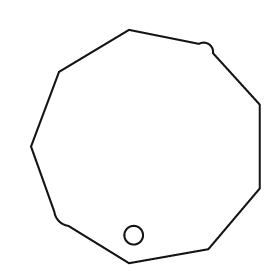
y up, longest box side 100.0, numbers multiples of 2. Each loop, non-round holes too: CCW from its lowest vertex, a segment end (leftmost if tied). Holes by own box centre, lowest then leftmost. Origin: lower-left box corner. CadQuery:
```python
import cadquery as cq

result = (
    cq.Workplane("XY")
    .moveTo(42.0, 0.0)
    .lineTo(76.0, 6.0)
    .lineTo(98.0, 32.0)
    .lineTo(98.0, 68.0)
    .lineTo(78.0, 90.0)
    .threePointArc((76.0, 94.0), (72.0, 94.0))
    .lineTo(42.0, 100.0)
    .lineTo(12.0, 82.0)
    .lineTo(0.0, 50.0)
    .lineTo(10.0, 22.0)
    .threePointArc((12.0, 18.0), (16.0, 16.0))
    .close()
    .moveTo(44.0, 12.0)
    .circle(4.0)
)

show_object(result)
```